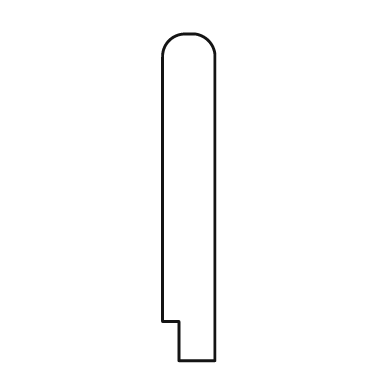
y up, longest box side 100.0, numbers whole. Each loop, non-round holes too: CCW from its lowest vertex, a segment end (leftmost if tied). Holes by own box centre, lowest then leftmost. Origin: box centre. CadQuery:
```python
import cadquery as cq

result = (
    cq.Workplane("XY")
    .moveTo(-3.0, -50.0)
    .lineTo(8.0, -50.0)
    .lineTo(8.0, 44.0)
    .threePointArc((6.0, 48.0), (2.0, 50.0))
    .lineTo(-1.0, 50.0)
    .threePointArc((-6.0, 48.0), (-8.0, 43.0))
    .lineTo(-8.0, -38.0)
    .lineTo(-3.0, -38.0)
    .close()
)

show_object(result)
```